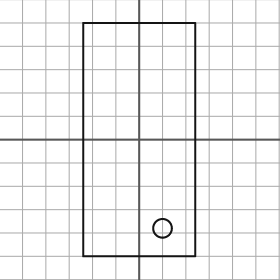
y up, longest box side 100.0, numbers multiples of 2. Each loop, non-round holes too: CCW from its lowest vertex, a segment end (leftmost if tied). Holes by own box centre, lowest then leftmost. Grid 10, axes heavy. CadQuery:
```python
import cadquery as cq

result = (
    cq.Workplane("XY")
    .moveTo(-24.0, -50.0)
    .lineTo(24.0, -50.0)
    .lineTo(24.0, 50.0)
    .lineTo(-24.0, 50.0)
    .close()
    .moveTo(10.0, -38.0)
    .circle(4.0)
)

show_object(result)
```